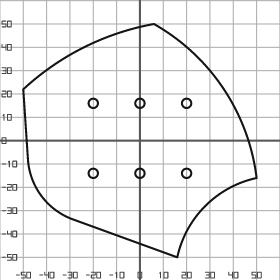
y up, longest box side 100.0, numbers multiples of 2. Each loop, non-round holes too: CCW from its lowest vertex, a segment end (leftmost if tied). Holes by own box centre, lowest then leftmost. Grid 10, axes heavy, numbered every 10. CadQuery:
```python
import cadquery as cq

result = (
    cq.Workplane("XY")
    .moveTo(16.0, -50.0)
    .threePointArc((28.0, -28.0), (50.0, -16.0))
    .threePointArc((36.0, 22.0), (6.0, 50.0))
    .threePointArc((-24.0, 40.0), (-50.0, 22.0))
    .lineTo(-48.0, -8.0)
    .threePointArc((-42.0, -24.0), (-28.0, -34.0))
    .close()
    .moveTo(-20.0, -14.0)
    .circle(2.0)
    .moveTo(0.0, -14.0)
    .circle(2.0)
    .moveTo(20.0, -14.0)
    .circle(2.0)
    .moveTo(-20.0, 16.0)
    .circle(2.0)
    .moveTo(0.0, 16.0)
    .circle(2.0)
    .moveTo(20.0, 16.0)
    .circle(2.0)
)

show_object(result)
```